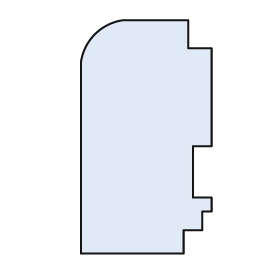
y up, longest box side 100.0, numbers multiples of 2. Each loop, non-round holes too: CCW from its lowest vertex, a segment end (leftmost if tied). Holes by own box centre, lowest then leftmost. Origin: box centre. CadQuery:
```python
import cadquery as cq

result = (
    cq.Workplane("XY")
    .moveTo(-28.0, -50.0)
    .lineTo(16.0, -50.0)
    .lineTo(16.0, -40.0)
    .lineTo(24.0, -40.0)
    .lineTo(24.0, -32.0)
    .lineTo(28.0, -32.0)
    .lineTo(28.0, -26.0)
    .lineTo(20.0, -26.0)
    .lineTo(20.0, -4.0)
    .lineTo(28.0, -4.0)
    .lineTo(28.0, 38.0)
    .lineTo(18.0, 38.0)
    .lineTo(18.0, 50.0)
    .lineTo(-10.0, 50.0)
    .threePointArc((-22.0, 44.0), (-28.0, 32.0))
    .close()
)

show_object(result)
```